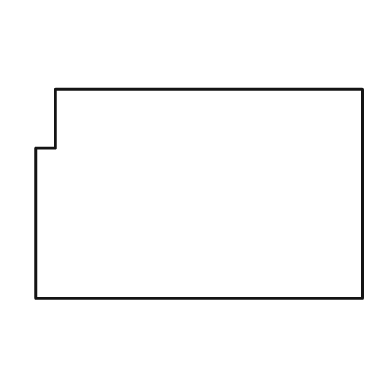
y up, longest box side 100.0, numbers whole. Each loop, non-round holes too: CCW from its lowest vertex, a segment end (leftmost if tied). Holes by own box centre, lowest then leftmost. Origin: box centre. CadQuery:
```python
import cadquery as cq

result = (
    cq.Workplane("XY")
    .moveTo(-50.0, -32.0)
    .lineTo(50.0, -32.0)
    .lineTo(50.0, 32.0)
    .lineTo(-44.0, 32.0)
    .lineTo(-44.0, 14.0)
    .lineTo(-50.0, 14.0)
    .close()
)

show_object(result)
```